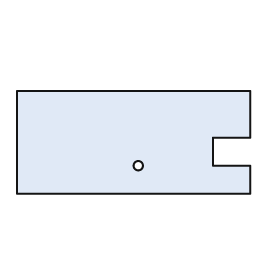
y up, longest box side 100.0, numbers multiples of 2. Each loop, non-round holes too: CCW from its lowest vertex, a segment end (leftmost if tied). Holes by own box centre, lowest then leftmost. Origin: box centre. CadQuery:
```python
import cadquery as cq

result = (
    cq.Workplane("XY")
    .moveTo(-50.0, -22.0)
    .lineTo(50.0, -22.0)
    .lineTo(50.0, -10.0)
    .lineTo(34.0, -10.0)
    .lineTo(34.0, 2.0)
    .lineTo(50.0, 2.0)
    .lineTo(50.0, 22.0)
    .lineTo(-50.0, 22.0)
    .close()
    .moveTo(2.0, -10.0)
    .circle(2.0)
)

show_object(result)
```